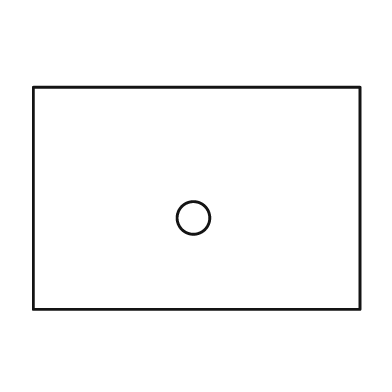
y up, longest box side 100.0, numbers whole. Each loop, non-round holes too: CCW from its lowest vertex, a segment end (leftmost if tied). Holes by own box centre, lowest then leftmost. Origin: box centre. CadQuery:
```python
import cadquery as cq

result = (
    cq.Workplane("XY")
    .moveTo(-50.0, -34.0)
    .lineTo(50.0, -34.0)
    .lineTo(50.0, 34.0)
    .lineTo(-50.0, 34.0)
    .close()
    .moveTo(-1.0, -6.0)
    .circle(5.0)
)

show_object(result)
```